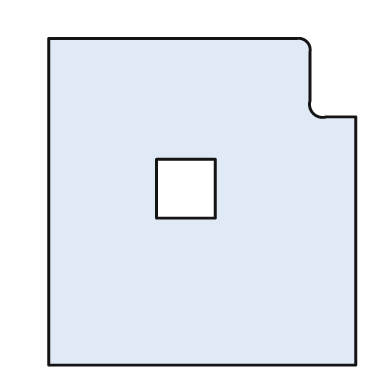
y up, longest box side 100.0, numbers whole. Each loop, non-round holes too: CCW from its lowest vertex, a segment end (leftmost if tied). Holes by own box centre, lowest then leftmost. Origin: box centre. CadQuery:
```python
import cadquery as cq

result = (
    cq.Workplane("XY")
    .moveTo(-47.0, -50.0)
    .lineTo(47.0, -50.0)
    .lineTo(47.0, 26.0)
    .lineTo(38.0, 26.0)
    .threePointArc((34.0, 27.0), (33.0, 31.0))
    .lineTo(33.0, 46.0)
    .threePointArc((32.0, 49.0), (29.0, 50.0))
    .lineTo(-47.0, 50.0)
    .close()
    .moveTo(-14.0, -5.0)
    .lineTo(4.0, -5.0)
    .lineTo(4.0, 13.0)
    .lineTo(-14.0, 13.0)
    .close()
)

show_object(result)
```